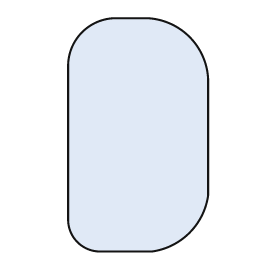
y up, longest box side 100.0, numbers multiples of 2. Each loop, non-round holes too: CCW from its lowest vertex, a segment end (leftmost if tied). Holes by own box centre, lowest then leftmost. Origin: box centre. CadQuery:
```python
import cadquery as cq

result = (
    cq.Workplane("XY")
    .moveTo(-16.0, -50.0)
    .lineTo(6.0, -50.0)
    .threePointArc((22.0, -42.0), (30.0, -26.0))
    .lineTo(30.0, 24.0)
    .threePointArc((22.0, 42.0), (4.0, 50.0))
    .lineTo(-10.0, 50.0)
    .threePointArc((-24.0, 44.0), (-30.0, 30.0))
    .lineTo(-30.0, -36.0)
    .threePointArc((-26.0, -46.0), (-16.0, -50.0))
    .close()
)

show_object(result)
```